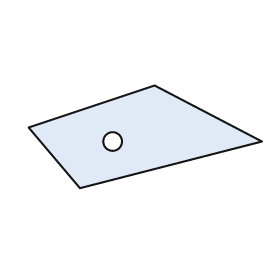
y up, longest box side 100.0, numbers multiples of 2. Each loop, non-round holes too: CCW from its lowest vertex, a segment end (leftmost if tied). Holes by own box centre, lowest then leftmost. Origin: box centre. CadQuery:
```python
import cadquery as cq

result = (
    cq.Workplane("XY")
    .moveTo(-28.0, -22.0)
    .lineTo(50.0, -2.0)
    .lineTo(4.0, 22.0)
    .lineTo(-50.0, 4.0)
    .close()
    .moveTo(-14.0, -2.0)
    .circle(4.0)
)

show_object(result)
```